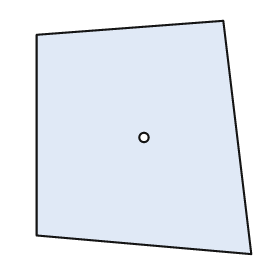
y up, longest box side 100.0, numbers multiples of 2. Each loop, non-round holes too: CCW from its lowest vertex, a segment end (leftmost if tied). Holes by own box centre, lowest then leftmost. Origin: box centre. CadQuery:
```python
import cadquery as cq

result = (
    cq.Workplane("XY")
    .moveTo(46.0, -50.0)
    .lineTo(34.0, 50.0)
    .lineTo(-46.0, 44.0)
    .lineTo(-46.0, -42.0)
    .close()
    .moveTo(0.0, 0.0)
    .circle(2.0)
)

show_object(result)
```